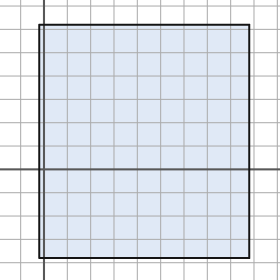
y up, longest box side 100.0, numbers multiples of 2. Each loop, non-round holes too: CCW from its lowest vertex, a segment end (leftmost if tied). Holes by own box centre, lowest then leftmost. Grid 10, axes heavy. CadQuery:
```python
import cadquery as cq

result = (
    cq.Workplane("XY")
    .moveTo(-2.0, -38.0)
    .lineTo(88.0, -38.0)
    .lineTo(88.0, 62.0)
    .lineTo(-2.0, 62.0)
    .close()
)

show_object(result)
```